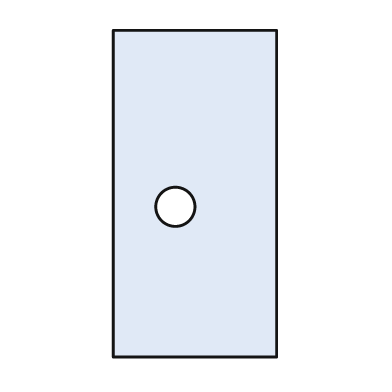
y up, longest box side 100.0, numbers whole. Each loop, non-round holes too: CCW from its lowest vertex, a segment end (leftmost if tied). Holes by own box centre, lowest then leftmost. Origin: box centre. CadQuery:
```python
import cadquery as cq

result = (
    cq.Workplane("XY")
    .moveTo(-25.0, -50.0)
    .lineTo(25.0, -50.0)
    .lineTo(25.0, 50.0)
    .lineTo(-25.0, 50.0)
    .close()
    .moveTo(-6.0, -4.0)
    .circle(6.0)
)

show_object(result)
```